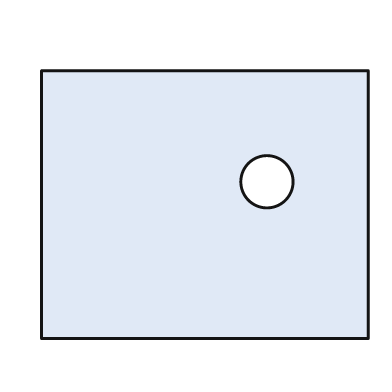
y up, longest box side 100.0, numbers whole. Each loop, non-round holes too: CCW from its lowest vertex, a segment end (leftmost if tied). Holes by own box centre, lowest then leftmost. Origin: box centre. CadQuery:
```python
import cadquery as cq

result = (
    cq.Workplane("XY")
    .moveTo(-50.0, -41.0)
    .lineTo(50.0, -41.0)
    .lineTo(50.0, 41.0)
    .lineTo(-50.0, 41.0)
    .close()
    .moveTo(19.0, 7.0)
    .circle(8.0)
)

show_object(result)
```